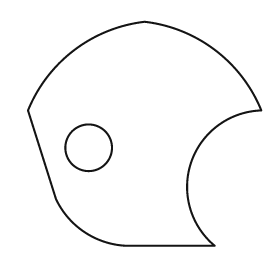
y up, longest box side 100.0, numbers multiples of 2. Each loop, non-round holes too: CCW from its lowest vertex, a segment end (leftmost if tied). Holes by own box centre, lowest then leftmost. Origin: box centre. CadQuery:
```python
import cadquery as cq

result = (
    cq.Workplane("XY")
    .moveTo(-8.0, -48.0)
    .lineTo(30.0, -48.0)
    .threePointArc((20.0, -12.0), (50.0, 10.0))
    .threePointArc((30.0, 36.0), (0.0, 48.0))
    .threePointArc((-30.0, 36.0), (-50.0, 10.0))
    .lineTo(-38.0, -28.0)
    .threePointArc((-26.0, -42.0), (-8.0, -48.0))
    .close()
    .moveTo(-24.0, -6.0)
    .circle(10.0)
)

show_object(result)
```